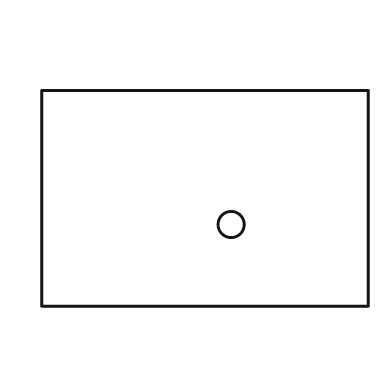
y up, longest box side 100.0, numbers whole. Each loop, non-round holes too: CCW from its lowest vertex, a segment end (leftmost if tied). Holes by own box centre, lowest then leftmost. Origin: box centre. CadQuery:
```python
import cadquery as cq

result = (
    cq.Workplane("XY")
    .moveTo(-50.0, -33.0)
    .lineTo(50.0, -33.0)
    .lineTo(50.0, 33.0)
    .lineTo(-50.0, 33.0)
    .close()
    .moveTo(8.0, -8.0)
    .circle(4.0)
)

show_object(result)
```